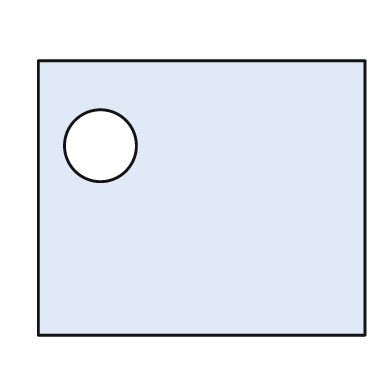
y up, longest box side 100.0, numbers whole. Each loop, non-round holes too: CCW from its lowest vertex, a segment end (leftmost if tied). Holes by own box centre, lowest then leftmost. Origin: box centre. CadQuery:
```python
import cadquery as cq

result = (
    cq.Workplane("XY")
    .moveTo(-50.0, -42.0)
    .lineTo(50.0, -42.0)
    .lineTo(50.0, 42.0)
    .lineTo(-50.0, 42.0)
    .close()
    .moveTo(-31.0, 16.0)
    .circle(11.0)
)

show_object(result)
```